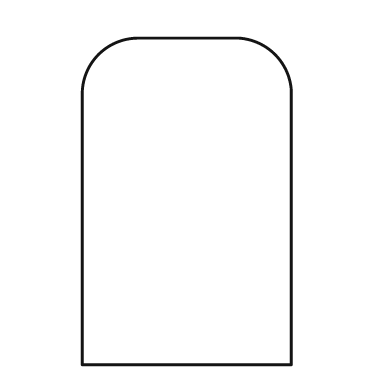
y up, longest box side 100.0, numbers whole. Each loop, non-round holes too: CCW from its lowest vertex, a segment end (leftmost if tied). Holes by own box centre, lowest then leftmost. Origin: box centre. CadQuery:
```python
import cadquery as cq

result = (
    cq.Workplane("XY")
    .moveTo(-32.0, -50.0)
    .lineTo(32.0, -50.0)
    .lineTo(32.0, 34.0)
    .threePointArc((27.0, 45.0), (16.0, 50.0))
    .lineTo(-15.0, 50.0)
    .threePointArc((-27.0, 45.0), (-32.0, 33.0))
    .close()
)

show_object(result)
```